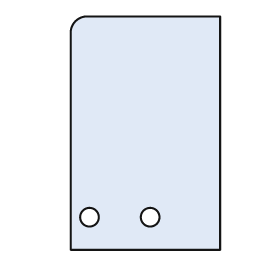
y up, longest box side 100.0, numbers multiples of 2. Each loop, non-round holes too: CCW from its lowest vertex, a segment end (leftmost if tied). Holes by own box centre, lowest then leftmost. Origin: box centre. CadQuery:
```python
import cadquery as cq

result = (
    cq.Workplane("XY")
    .moveTo(-32.0, -50.0)
    .lineTo(32.0, -50.0)
    .lineTo(32.0, 50.0)
    .lineTo(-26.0, 50.0)
    .threePointArc((-30.0, 48.0), (-32.0, 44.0))
    .close()
    .moveTo(-24.0, -36.0)
    .circle(4.0)
    .moveTo(2.0, -36.0)
    .circle(4.0)
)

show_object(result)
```